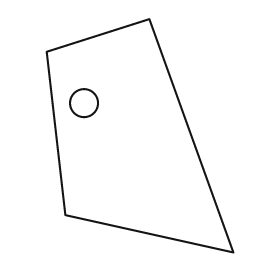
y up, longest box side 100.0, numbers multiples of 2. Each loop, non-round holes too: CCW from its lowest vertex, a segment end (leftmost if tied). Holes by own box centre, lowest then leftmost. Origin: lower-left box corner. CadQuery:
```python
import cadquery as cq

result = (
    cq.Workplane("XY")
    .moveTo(80.0, 0.0)
    .lineTo(44.0, 100.0)
    .lineTo(0.0, 86.0)
    .lineTo(8.0, 16.0)
    .close()
    .moveTo(16.0, 64.0)
    .circle(6.0)
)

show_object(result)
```